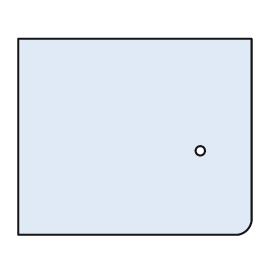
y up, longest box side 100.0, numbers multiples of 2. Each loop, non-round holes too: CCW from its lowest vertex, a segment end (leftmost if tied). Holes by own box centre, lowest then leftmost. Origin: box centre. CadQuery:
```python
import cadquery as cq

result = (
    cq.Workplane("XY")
    .moveTo(-50.0, -42.0)
    .lineTo(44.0, -42.0)
    .threePointArc((48.0, -40.0), (50.0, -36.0))
    .lineTo(50.0, 42.0)
    .lineTo(-50.0, 42.0)
    .close()
    .moveTo(28.0, -6.0)
    .circle(2.0)
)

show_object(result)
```